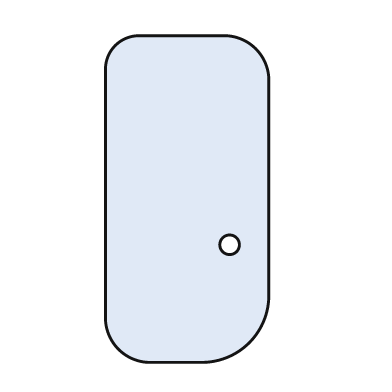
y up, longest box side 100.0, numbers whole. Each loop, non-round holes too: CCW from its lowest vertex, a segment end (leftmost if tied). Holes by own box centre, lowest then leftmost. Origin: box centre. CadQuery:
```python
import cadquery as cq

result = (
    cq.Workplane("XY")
    .moveTo(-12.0, -50.0)
    .lineTo(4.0, -50.0)
    .threePointArc((19.0, -44.0), (25.0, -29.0))
    .lineTo(25.0, 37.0)
    .threePointArc((21.0, 46.0), (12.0, 50.0))
    .lineTo(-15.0, 50.0)
    .threePointArc((-22.0, 47.0), (-25.0, 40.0))
    .lineTo(-25.0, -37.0)
    .threePointArc((-21.0, -46.0), (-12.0, -50.0))
    .close()
    .moveTo(13.0, -14.0)
    .circle(3.0)
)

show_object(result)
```